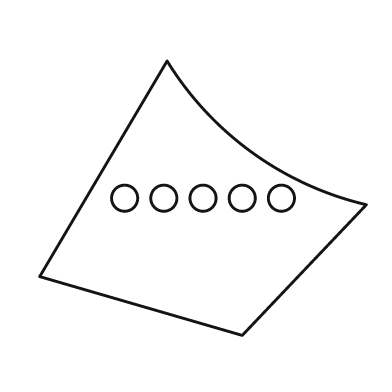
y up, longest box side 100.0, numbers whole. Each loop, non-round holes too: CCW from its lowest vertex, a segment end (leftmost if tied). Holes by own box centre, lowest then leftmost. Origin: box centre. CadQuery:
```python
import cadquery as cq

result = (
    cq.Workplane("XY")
    .moveTo(12.0, -42.0)
    .lineTo(50.0, -2.0)
    .threePointArc((15.0, 14.0), (-11.0, 42.0))
    .lineTo(-50.0, -24.0)
    .close()
    .moveTo(-24.0, 0.0)
    .circle(4.0)
    .moveTo(-12.0, 0.0)
    .circle(4.0)
    .moveTo(0.0, 0.0)
    .circle(4.0)
    .moveTo(12.0, 0.0)
    .circle(4.0)
    .moveTo(24.0, 0.0)
    .circle(4.0)
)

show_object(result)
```